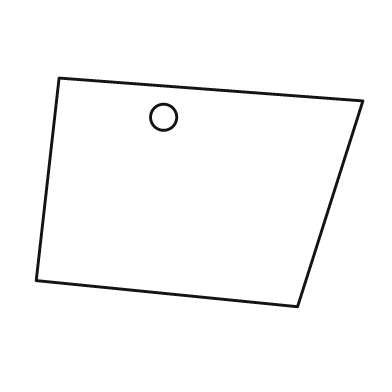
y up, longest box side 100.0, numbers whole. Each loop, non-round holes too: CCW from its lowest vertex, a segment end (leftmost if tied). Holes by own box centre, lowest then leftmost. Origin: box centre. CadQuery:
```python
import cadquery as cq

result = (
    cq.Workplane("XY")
    .moveTo(30.0, -35.0)
    .lineTo(50.0, 28.0)
    .lineTo(-43.0, 35.0)
    .lineTo(-50.0, -27.0)
    .close()
    .moveTo(-11.0, 23.0)
    .circle(4.0)
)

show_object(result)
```